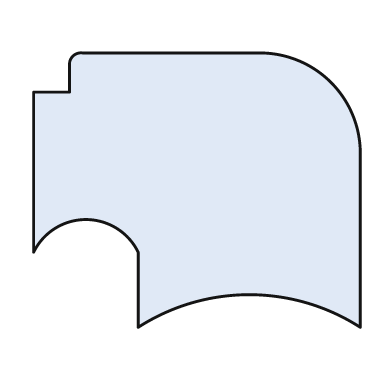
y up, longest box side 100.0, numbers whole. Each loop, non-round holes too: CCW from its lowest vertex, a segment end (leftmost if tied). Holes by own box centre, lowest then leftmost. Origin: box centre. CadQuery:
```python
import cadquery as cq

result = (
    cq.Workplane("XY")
    .moveTo(-18.0, -42.0)
    .threePointArc((16.0, -32.0), (50.0, -42.0))
    .lineTo(50.0, 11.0)
    .threePointArc((41.0, 33.0), (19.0, 42.0))
    .lineTo(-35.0, 42.0)
    .threePointArc((-38.0, 41.0), (-39.0, 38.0))
    .lineTo(-39.0, 30.0)
    .lineTo(-50.0, 30.0)
    .lineTo(-50.0, -19.0)
    .threePointArc((-34.0, -9.0), (-18.0, -19.0))
    .close()
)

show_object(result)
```